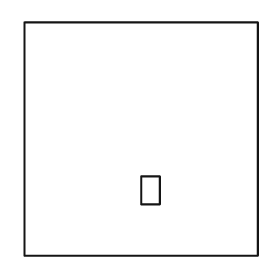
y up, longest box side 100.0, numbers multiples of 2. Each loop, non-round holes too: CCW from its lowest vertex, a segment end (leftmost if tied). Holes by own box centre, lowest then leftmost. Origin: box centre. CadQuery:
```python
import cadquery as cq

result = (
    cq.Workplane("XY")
    .moveTo(-50.0, -50.0)
    .lineTo(50.0, -50.0)
    .lineTo(50.0, 50.0)
    .lineTo(-50.0, 50.0)
    .close()
    .moveTo(0.0, -28.0)
    .lineTo(8.0, -28.0)
    .lineTo(8.0, -16.0)
    .lineTo(0.0, -16.0)
    .close()
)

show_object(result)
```